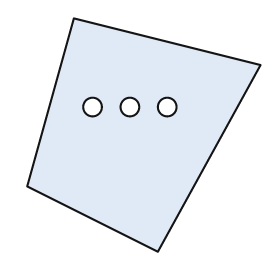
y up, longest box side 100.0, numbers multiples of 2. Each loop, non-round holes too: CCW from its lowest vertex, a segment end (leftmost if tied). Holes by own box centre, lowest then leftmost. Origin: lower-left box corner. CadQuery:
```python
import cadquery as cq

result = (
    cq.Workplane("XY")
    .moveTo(56.0, 0.0)
    .lineTo(100.0, 80.0)
    .lineTo(20.0, 100.0)
    .lineTo(0.0, 28.0)
    .close()
    .moveTo(28.0, 62.0)
    .circle(4.0)
    .moveTo(44.0, 62.0)
    .circle(4.0)
    .moveTo(60.0, 62.0)
    .circle(4.0)
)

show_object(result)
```